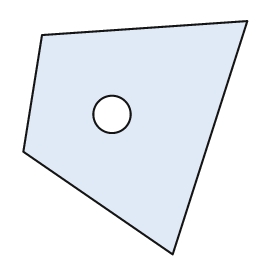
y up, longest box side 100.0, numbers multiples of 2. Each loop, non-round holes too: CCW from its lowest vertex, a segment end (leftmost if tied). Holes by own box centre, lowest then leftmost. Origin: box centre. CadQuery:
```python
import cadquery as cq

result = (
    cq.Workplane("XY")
    .moveTo(16.0, -50.0)
    .lineTo(48.0, 50.0)
    .lineTo(-40.0, 44.0)
    .lineTo(-48.0, -6.0)
    .close()
    .moveTo(-10.0, 10.0)
    .circle(8.0)
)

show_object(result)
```